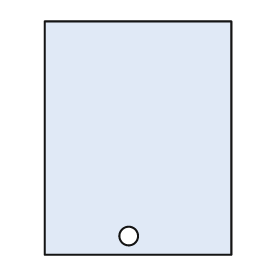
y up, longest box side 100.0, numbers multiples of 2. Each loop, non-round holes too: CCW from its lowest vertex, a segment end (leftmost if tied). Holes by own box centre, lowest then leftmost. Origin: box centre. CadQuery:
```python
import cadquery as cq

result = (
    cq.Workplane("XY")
    .moveTo(-40.0, -50.0)
    .lineTo(40.0, -50.0)
    .lineTo(40.0, 50.0)
    .lineTo(-40.0, 50.0)
    .close()
    .moveTo(-4.0, -42.0)
    .circle(4.0)
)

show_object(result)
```